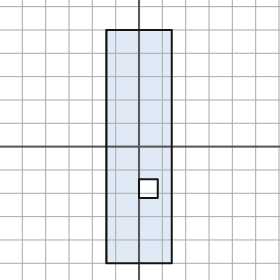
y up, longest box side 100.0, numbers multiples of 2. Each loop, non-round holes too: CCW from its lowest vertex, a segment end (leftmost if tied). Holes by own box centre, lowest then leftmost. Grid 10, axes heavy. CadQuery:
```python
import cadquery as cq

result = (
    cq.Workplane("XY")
    .moveTo(-14.0, -50.0)
    .lineTo(14.0, -50.0)
    .lineTo(14.0, 50.0)
    .lineTo(-14.0, 50.0)
    .close()
    .moveTo(0.0, -22.0)
    .lineTo(8.0, -22.0)
    .lineTo(8.0, -14.0)
    .lineTo(0.0, -14.0)
    .close()
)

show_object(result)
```